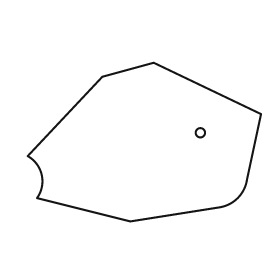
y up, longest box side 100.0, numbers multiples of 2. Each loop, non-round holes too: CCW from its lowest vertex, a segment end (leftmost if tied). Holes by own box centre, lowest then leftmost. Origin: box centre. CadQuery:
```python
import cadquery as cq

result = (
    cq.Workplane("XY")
    .moveTo(-6.0, -34.0)
    .lineTo(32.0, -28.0)
    .threePointArc((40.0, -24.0), (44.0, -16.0))
    .lineTo(50.0, 12.0)
    .lineTo(4.0, 34.0)
    .lineTo(-18.0, 28.0)
    .lineTo(-50.0, -6.0)
    .threePointArc((-44.0, -14.0), (-46.0, -24.0))
    .close()
    .moveTo(24.0, 4.0)
    .circle(2.0)
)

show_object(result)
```